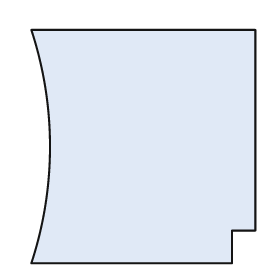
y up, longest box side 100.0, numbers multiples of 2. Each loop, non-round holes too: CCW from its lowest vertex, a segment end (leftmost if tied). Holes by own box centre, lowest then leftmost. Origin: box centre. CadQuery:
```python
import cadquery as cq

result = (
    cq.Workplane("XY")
    .moveTo(-48.0, -50.0)
    .lineTo(38.0, -50.0)
    .lineTo(38.0, -36.0)
    .lineTo(48.0, -36.0)
    .lineTo(48.0, 50.0)
    .lineTo(-48.0, 50.0)
    .threePointArc((-40.0, 0.0), (-48.0, -50.0))
    .close()
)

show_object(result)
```